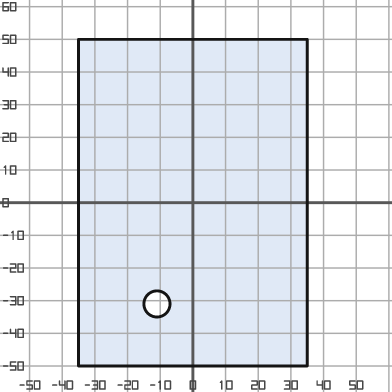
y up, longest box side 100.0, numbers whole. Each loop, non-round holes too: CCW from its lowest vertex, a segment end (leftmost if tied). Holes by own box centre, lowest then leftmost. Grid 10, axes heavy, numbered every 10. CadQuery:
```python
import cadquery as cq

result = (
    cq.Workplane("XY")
    .moveTo(-35.0, -50.0)
    .lineTo(35.0, -50.0)
    .lineTo(35.0, 50.0)
    .lineTo(-35.0, 50.0)
    .close()
    .moveTo(-11.0, -31.0)
    .circle(4.0)
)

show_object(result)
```